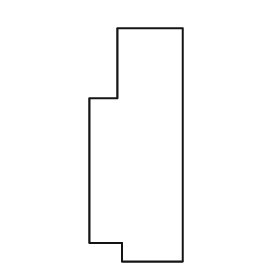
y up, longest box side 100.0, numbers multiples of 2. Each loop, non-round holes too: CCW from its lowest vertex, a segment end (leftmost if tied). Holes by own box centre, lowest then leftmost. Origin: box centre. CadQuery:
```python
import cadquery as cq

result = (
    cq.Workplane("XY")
    .moveTo(-6.0, -50.0)
    .lineTo(20.0, -50.0)
    .lineTo(20.0, 50.0)
    .lineTo(-8.0, 50.0)
    .lineTo(-8.0, 20.0)
    .lineTo(-20.0, 20.0)
    .lineTo(-20.0, -42.0)
    .lineTo(-6.0, -42.0)
    .close()
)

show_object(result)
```